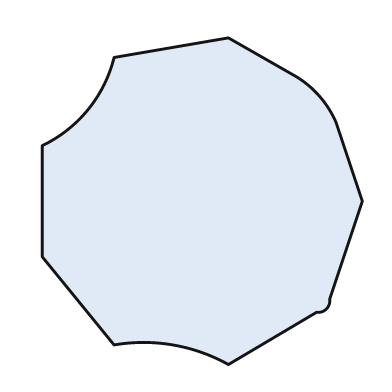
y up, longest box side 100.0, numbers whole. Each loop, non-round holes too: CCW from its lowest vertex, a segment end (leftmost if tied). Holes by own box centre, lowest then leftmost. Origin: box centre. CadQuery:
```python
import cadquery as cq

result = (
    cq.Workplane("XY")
    .moveTo(8.0, -50.0)
    .lineTo(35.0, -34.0)
    .threePointArc((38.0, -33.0), (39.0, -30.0))
    .lineTo(49.0, 0.0)
    .lineTo(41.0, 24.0)
    .threePointArc((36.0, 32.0), (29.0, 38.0))
    .lineTo(8.0, 50.0)
    .lineTo(-27.0, 44.0)
    .threePointArc((-35.0, 28.0), (-49.0, 17.0))
    .lineTo(-49.0, -17.0)
    .lineTo(-27.0, -44.0)
    .threePointArc((-9.0, -44.0), (8.0, -50.0))
    .close()
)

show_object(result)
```